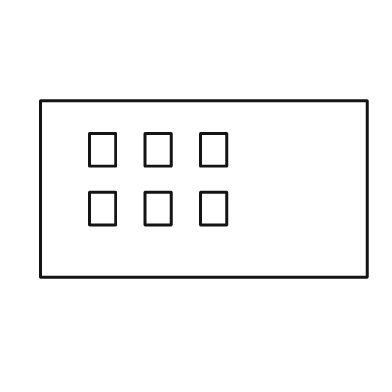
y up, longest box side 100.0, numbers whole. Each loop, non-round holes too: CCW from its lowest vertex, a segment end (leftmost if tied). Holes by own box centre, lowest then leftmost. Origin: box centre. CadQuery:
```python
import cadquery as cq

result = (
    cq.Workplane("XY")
    .moveTo(-50.0, -27.0)
    .lineTo(50.0, -27.0)
    .lineTo(50.0, 27.0)
    .lineTo(-50.0, 27.0)
    .close()
    .moveTo(-35.0, -11.0)
    .lineTo(-27.0, -11.0)
    .lineTo(-27.0, -1.0)
    .lineTo(-35.0, -1.0)
    .close()
    .moveTo(-18.0, -11.0)
    .lineTo(-10.0, -11.0)
    .lineTo(-10.0, -1.0)
    .lineTo(-18.0, -1.0)
    .close()
    .moveTo(-1.0, -11.0)
    .lineTo(7.0, -11.0)
    .lineTo(7.0, -1.0)
    .lineTo(-1.0, -1.0)
    .close()
    .moveTo(-35.0, 7.0)
    .lineTo(-27.0, 7.0)
    .lineTo(-27.0, 17.0)
    .lineTo(-35.0, 17.0)
    .close()
    .moveTo(-18.0, 7.0)
    .lineTo(-10.0, 7.0)
    .lineTo(-10.0, 17.0)
    .lineTo(-18.0, 17.0)
    .close()
    .moveTo(-1.0, 7.0)
    .lineTo(7.0, 7.0)
    .lineTo(7.0, 17.0)
    .lineTo(-1.0, 17.0)
    .close()
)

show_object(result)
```